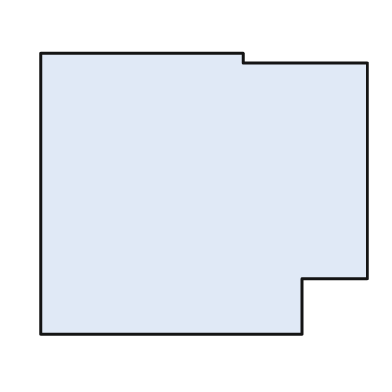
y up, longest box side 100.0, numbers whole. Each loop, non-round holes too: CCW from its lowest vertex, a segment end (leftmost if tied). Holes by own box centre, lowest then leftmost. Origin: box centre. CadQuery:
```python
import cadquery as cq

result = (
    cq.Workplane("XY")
    .moveTo(-50.0, -43.0)
    .lineTo(30.0, -43.0)
    .lineTo(30.0, -26.0)
    .lineTo(50.0, -26.0)
    .lineTo(50.0, 40.0)
    .lineTo(12.0, 40.0)
    .lineTo(12.0, 43.0)
    .lineTo(-50.0, 43.0)
    .close()
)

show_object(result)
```